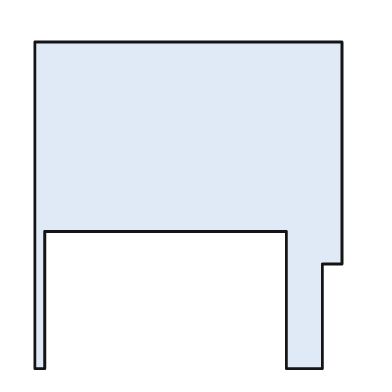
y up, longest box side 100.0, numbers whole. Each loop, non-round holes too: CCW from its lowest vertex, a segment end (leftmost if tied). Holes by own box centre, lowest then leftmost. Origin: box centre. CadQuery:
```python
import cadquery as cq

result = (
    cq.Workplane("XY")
    .moveTo(-47.0, -50.0)
    .lineTo(-44.0, -50.0)
    .lineTo(-44.0, -8.0)
    .lineTo(30.0, -8.0)
    .lineTo(30.0, -50.0)
    .lineTo(41.0, -50.0)
    .lineTo(41.0, -18.0)
    .lineTo(47.0, -18.0)
    .lineTo(47.0, 50.0)
    .lineTo(-47.0, 50.0)
    .close()
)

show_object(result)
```